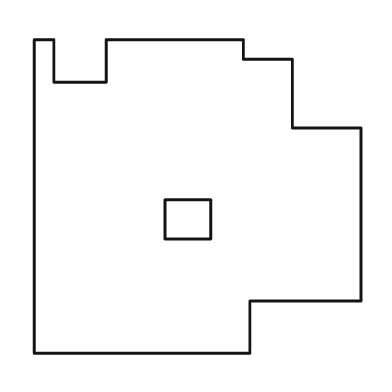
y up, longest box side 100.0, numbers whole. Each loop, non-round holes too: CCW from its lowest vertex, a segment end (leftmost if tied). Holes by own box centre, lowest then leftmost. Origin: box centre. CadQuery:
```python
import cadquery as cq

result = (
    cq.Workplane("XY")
    .moveTo(-50.0, -48.0)
    .lineTo(16.0, -48.0)
    .lineTo(16.0, -32.0)
    .lineTo(50.0, -32.0)
    .lineTo(50.0, 21.0)
    .lineTo(29.0, 21.0)
    .lineTo(29.0, 42.0)
    .lineTo(14.0, 42.0)
    .lineTo(14.0, 48.0)
    .lineTo(-28.0, 48.0)
    .lineTo(-28.0, 35.0)
    .lineTo(-44.0, 35.0)
    .lineTo(-44.0, 48.0)
    .lineTo(-50.0, 48.0)
    .close()
    .moveTo(-10.0, -13.0)
    .lineTo(4.0, -13.0)
    .lineTo(4.0, -1.0)
    .lineTo(-10.0, -1.0)
    .close()
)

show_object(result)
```